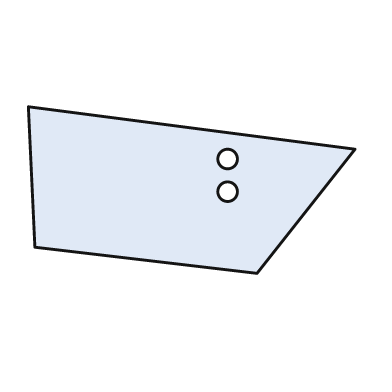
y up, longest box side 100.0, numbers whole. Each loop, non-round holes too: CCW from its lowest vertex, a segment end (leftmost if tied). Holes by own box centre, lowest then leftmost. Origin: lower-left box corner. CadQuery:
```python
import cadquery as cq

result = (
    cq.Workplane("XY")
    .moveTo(70.0, 0.0)
    .lineTo(100.0, 38.0)
    .lineTo(0.0, 51.0)
    .lineTo(2.0, 8.0)
    .close()
    .moveTo(61.0, 25.0)
    .circle(3.0)
    .moveTo(61.0, 35.0)
    .circle(3.0)
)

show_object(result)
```